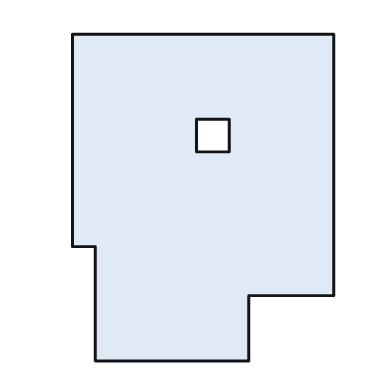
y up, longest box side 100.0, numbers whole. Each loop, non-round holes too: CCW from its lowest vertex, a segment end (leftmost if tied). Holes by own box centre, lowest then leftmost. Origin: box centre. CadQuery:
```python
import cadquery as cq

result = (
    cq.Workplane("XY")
    .moveTo(-33.0, -50.0)
    .lineTo(14.0, -50.0)
    .lineTo(14.0, -30.0)
    .lineTo(40.0, -30.0)
    .lineTo(40.0, 50.0)
    .lineTo(-40.0, 50.0)
    .lineTo(-40.0, -15.0)
    .lineTo(-33.0, -15.0)
    .close()
    .moveTo(-2.0, 14.0)
    .lineTo(8.0, 14.0)
    .lineTo(8.0, 24.0)
    .lineTo(-2.0, 24.0)
    .close()
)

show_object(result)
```